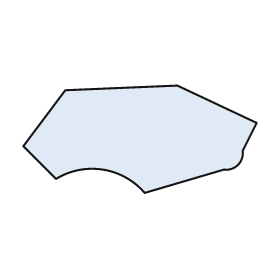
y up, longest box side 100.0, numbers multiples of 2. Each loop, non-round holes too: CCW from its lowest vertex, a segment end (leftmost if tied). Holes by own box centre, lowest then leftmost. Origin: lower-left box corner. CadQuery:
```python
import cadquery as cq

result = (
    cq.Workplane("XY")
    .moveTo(52.0, 0.0)
    .lineTo(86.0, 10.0)
    .threePointArc((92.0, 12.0), (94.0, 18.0))
    .lineTo(100.0, 30.0)
    .lineTo(66.0, 46.0)
    .lineTo(18.0, 44.0)
    .lineTo(0.0, 20.0)
    .lineTo(14.0, 6.0)
    .threePointArc((34.0, 10.0), (52.0, 0.0))
    .close()
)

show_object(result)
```